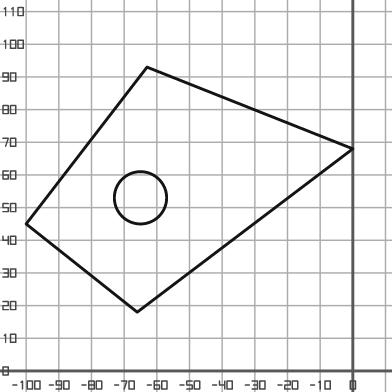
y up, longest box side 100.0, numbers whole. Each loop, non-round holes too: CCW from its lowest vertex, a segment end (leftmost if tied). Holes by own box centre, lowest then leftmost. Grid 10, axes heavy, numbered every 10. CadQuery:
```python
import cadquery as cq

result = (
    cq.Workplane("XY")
    .moveTo(-66.0, 18.0)
    .lineTo(0.0, 68.0)
    .lineTo(-63.0, 93.0)
    .lineTo(-100.0, 45.0)
    .close()
    .moveTo(-65.0, 53.0)
    .circle(8.0)
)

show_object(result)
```